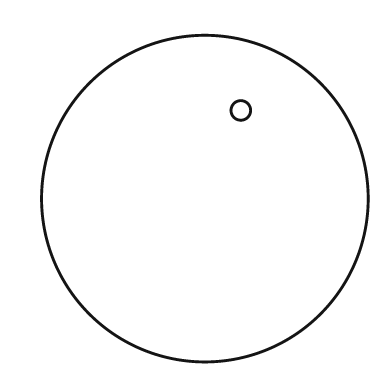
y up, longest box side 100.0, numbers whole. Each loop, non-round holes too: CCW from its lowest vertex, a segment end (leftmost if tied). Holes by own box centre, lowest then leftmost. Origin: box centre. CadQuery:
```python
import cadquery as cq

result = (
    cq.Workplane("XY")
    .moveTo(0.0, 0.0)
    .circle(50.0)
    .moveTo(11.0, 27.0)
    .circle(3.0)
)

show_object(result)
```